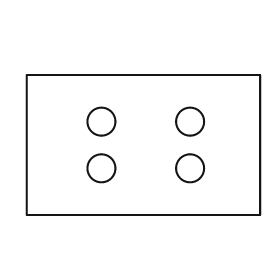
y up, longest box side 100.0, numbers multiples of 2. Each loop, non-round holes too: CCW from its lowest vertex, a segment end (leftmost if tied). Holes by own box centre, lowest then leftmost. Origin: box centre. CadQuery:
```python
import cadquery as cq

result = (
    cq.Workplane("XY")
    .moveTo(-50.0, -30.0)
    .lineTo(50.0, -30.0)
    .lineTo(50.0, 30.0)
    .lineTo(-50.0, 30.0)
    .close()
    .moveTo(-18.0, -10.0)
    .circle(6.0)
    .moveTo(20.0, -10.0)
    .circle(6.0)
    .moveTo(-18.0, 10.0)
    .circle(6.0)
    .moveTo(20.0, 10.0)
    .circle(6.0)
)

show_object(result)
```